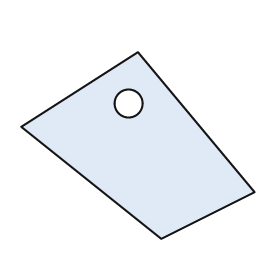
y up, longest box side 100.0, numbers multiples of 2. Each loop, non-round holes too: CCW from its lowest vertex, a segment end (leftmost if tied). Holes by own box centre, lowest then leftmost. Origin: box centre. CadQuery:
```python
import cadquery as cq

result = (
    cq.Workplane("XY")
    .moveTo(10.0, -40.0)
    .lineTo(50.0, -20.0)
    .lineTo(0.0, 40.0)
    .lineTo(-50.0, 8.0)
    .close()
    .moveTo(-4.0, 18.0)
    .circle(6.0)
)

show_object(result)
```